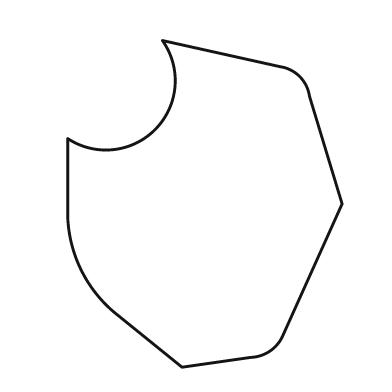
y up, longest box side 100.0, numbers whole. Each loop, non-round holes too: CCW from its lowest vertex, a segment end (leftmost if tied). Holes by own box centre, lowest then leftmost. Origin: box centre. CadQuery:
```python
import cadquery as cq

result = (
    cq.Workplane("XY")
    .moveTo(-7.0, -50.0)
    .lineTo(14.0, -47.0)
    .threePointArc((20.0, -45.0), (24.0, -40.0))
    .lineTo(42.0, 0.0)
    .lineTo(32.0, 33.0)
    .threePointArc((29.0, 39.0), (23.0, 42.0))
    .lineTo(-13.0, 50.0)
    .threePointArc((-15.0, 23.0), (-42.0, 20.0))
    .lineTo(-42.0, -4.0)
    .threePointArc((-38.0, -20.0), (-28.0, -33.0))
    .close()
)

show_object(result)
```